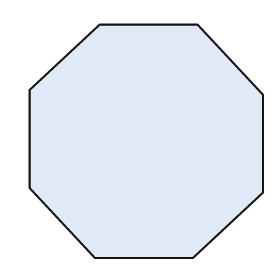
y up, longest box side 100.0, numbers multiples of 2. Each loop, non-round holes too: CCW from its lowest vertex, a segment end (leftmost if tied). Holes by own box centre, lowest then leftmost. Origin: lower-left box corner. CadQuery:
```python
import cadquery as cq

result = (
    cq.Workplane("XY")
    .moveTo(28.0, 0.0)
    .lineTo(70.0, 0.0)
    .lineTo(100.0, 28.0)
    .lineTo(100.0, 70.0)
    .lineTo(72.0, 100.0)
    .lineTo(30.0, 100.0)
    .lineTo(0.0, 72.0)
    .lineTo(0.0, 30.0)
    .close()
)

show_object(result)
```